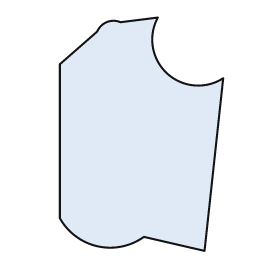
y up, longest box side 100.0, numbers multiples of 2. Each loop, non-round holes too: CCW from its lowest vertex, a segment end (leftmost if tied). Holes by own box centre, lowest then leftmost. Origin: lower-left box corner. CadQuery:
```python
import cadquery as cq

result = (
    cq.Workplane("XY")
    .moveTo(62.0, 0.0)
    .lineTo(70.0, 74.0)
    .threePointArc((46.0, 76.0), (42.0, 100.0))
    .lineTo(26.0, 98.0)
    .threePointArc((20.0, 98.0), (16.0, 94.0))
    .lineTo(0.0, 80.0)
    .lineTo(0.0, 14.0)
    .threePointArc((16.0, 2.0), (36.0, 6.0))
    .close()
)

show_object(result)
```